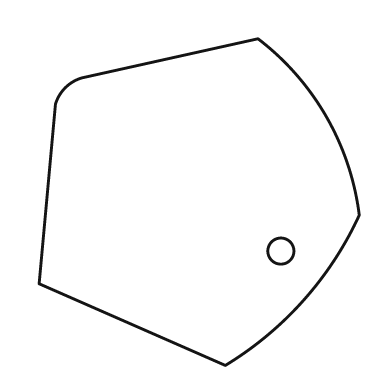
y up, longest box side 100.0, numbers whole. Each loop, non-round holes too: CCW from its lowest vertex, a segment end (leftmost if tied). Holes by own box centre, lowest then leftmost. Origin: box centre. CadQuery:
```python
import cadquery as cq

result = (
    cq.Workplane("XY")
    .moveTo(8.0, -50.0)
    .threePointArc((32.0, -30.0), (49.0, -4.0))
    .threePointArc((39.0, 26.0), (18.0, 50.0))
    .lineTo(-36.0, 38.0)
    .threePointArc((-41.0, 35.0), (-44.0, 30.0))
    .lineTo(-49.0, -25.0)
    .close()
    .moveTo(25.0, -15.0)
    .circle(4.0)
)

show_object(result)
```